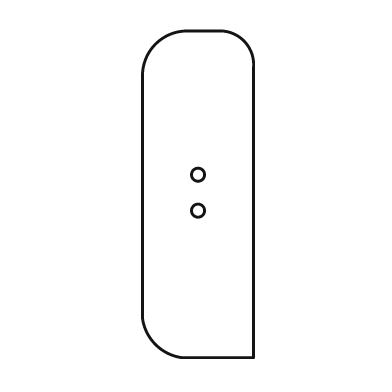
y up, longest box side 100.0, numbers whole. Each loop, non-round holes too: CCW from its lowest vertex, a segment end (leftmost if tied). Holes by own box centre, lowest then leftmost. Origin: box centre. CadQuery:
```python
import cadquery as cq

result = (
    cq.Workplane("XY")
    .moveTo(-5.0, -50.0)
    .lineTo(17.0, -50.0)
    .lineTo(17.0, 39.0)
    .threePointArc((14.0, 47.0), (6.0, 50.0))
    .lineTo(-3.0, 50.0)
    .threePointArc((-13.0, 46.0), (-17.0, 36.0))
    .lineTo(-17.0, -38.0)
    .threePointArc((-13.0, -46.0), (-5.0, -50.0))
    .close()
    .moveTo(0.0, -5.0)
    .circle(2.0)
    .moveTo(0.0, 6.0)
    .circle(2.0)
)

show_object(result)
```